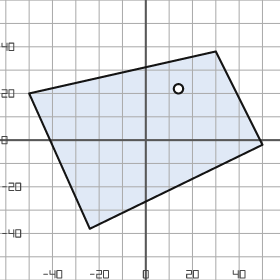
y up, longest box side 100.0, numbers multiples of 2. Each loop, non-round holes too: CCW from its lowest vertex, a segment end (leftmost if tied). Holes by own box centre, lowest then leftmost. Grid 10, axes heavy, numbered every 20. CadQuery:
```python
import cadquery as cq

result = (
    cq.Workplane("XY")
    .moveTo(-24.0, -38.0)
    .lineTo(50.0, -2.0)
    .lineTo(30.0, 38.0)
    .lineTo(-50.0, 20.0)
    .close()
    .moveTo(14.0, 22.0)
    .circle(2.0)
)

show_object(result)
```